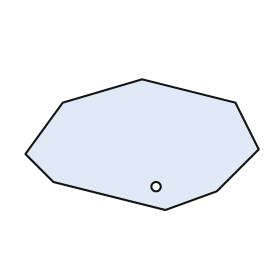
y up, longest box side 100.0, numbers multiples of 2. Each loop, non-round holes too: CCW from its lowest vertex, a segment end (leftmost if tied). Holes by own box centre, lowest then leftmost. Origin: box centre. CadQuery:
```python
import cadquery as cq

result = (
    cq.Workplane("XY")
    .moveTo(10.0, -28.0)
    .lineTo(32.0, -20.0)
    .lineTo(50.0, -2.0)
    .lineTo(40.0, 18.0)
    .lineTo(0.0, 28.0)
    .lineTo(-34.0, 18.0)
    .lineTo(-50.0, -4.0)
    .lineTo(-38.0, -16.0)
    .close()
    .moveTo(6.0, -18.0)
    .circle(2.0)
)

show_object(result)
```